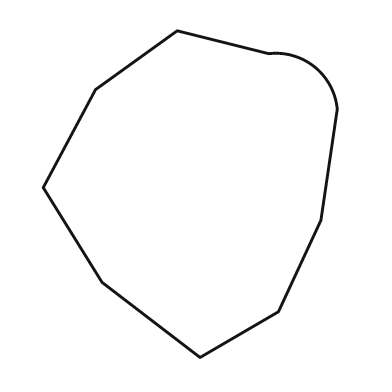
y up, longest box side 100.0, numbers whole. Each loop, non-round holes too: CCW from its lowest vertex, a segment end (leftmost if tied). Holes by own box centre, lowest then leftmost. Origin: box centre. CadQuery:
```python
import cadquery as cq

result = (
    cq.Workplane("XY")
    .moveTo(3.0, -50.0)
    .lineTo(27.0, -36.0)
    .lineTo(40.0, -8.0)
    .lineTo(45.0, 26.0)
    .threePointArc((38.0, 39.0), (24.0, 43.0))
    .lineTo(-4.0, 50.0)
    .lineTo(-29.0, 32.0)
    .lineTo(-45.0, 2.0)
    .lineTo(-27.0, -27.0)
    .close()
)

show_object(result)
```